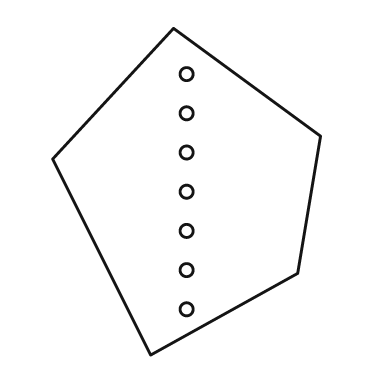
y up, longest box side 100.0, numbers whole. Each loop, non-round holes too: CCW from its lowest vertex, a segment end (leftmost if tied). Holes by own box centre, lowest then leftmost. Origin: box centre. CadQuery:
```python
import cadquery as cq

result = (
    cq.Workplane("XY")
    .moveTo(-11.0, -50.0)
    .lineTo(34.0, -25.0)
    .lineTo(41.0, 17.0)
    .lineTo(-4.0, 50.0)
    .lineTo(-41.0, 10.0)
    .close()
    .moveTo(0.0, -36.0)
    .circle(2.0)
    .moveTo(0.0, -24.0)
    .circle(2.0)
    .moveTo(0.0, -12.0)
    .circle(2.0)
    .moveTo(0.0, 0.0)
    .circle(2.0)
    .moveTo(0.0, 12.0)
    .circle(2.0)
    .moveTo(0.0, 24.0)
    .circle(2.0)
    .moveTo(0.0, 36.0)
    .circle(2.0)
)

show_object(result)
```